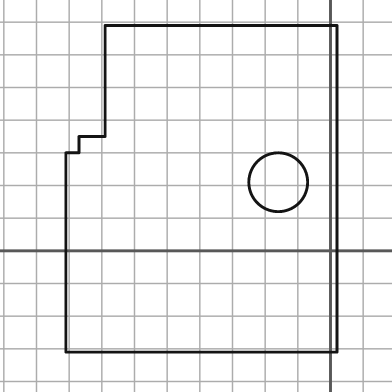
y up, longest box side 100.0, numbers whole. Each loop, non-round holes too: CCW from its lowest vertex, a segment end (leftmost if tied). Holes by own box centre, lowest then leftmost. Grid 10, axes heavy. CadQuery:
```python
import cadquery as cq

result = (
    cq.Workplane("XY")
    .moveTo(-81.0, -31.0)
    .lineTo(2.0, -31.0)
    .lineTo(2.0, 69.0)
    .lineTo(-69.0, 69.0)
    .lineTo(-69.0, 35.0)
    .lineTo(-77.0, 35.0)
    .lineTo(-77.0, 30.0)
    .lineTo(-81.0, 30.0)
    .close()
    .moveTo(-16.0, 21.0)
    .circle(9.0)
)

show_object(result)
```